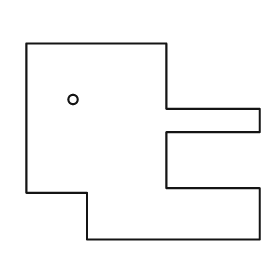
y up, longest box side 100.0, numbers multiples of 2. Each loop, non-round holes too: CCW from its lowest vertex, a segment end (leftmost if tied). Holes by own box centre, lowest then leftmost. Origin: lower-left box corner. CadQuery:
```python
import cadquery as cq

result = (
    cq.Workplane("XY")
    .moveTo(26.0, 0.0)
    .lineTo(100.0, 0.0)
    .lineTo(100.0, 22.0)
    .lineTo(60.0, 22.0)
    .lineTo(60.0, 46.0)
    .lineTo(100.0, 46.0)
    .lineTo(100.0, 56.0)
    .lineTo(60.0, 56.0)
    .lineTo(60.0, 84.0)
    .lineTo(0.0, 84.0)
    .lineTo(0.0, 20.0)
    .lineTo(26.0, 20.0)
    .close()
    .moveTo(20.0, 60.0)
    .circle(2.0)
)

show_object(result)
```